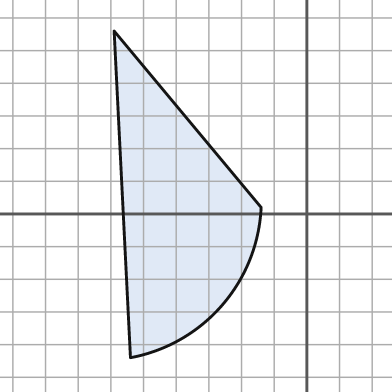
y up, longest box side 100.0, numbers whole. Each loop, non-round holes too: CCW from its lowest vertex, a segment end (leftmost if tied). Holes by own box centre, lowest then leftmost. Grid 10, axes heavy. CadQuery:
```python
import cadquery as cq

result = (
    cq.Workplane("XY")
    .moveTo(-54.0, -44.0)
    .threePointArc((-26.0, -28.0), (-14.0, 2.0))
    .lineTo(-59.0, 56.0)
    .close()
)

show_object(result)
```